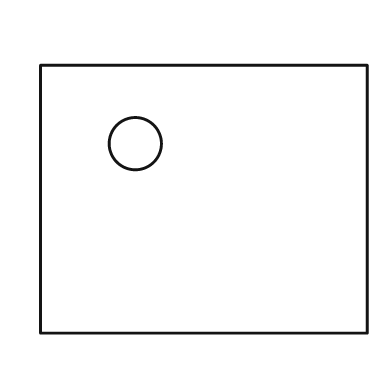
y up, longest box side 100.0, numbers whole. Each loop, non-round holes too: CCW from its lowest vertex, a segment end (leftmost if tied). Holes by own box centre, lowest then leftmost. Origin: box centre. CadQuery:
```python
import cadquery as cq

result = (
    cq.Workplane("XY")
    .moveTo(-50.0, -41.0)
    .lineTo(50.0, -41.0)
    .lineTo(50.0, 41.0)
    .lineTo(-50.0, 41.0)
    .close()
    .moveTo(-21.0, 17.0)
    .circle(8.0)
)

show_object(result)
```